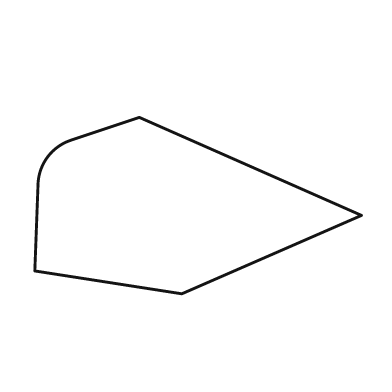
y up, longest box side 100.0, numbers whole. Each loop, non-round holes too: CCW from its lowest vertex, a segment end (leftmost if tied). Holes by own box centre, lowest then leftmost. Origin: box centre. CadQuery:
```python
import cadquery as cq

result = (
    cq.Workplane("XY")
    .moveTo(-5.0, -27.0)
    .lineTo(50.0, -3.0)
    .lineTo(-18.0, 27.0)
    .lineTo(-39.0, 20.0)
    .threePointArc((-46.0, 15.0), (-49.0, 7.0))
    .lineTo(-50.0, -20.0)
    .close()
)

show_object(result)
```